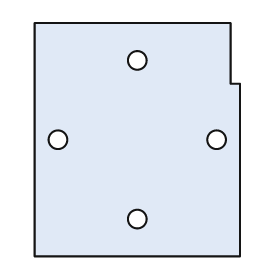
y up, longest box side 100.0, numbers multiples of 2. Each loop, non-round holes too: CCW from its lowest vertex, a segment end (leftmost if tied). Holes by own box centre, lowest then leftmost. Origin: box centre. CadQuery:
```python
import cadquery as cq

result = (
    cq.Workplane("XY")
    .moveTo(-44.0, -50.0)
    .lineTo(44.0, -50.0)
    .lineTo(44.0, 24.0)
    .lineTo(40.0, 24.0)
    .lineTo(40.0, 50.0)
    .lineTo(-44.0, 50.0)
    .close()
    .moveTo(0.0, -34.0)
    .circle(4.0)
    .moveTo(-34.0, 0.0)
    .circle(4.0)
    .moveTo(34.0, 0.0)
    .circle(4.0)
    .moveTo(0.0, 34.0)
    .circle(4.0)
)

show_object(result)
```